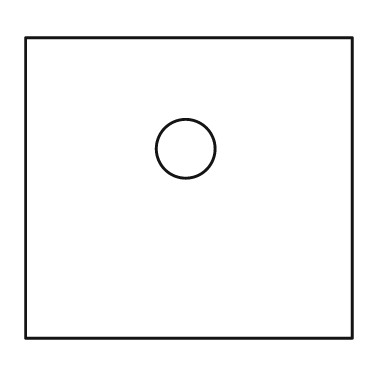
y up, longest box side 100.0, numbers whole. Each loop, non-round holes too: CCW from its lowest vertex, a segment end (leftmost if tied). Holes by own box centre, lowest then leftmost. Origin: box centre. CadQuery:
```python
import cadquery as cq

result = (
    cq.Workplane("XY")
    .moveTo(-50.0, -46.0)
    .lineTo(50.0, -46.0)
    .lineTo(50.0, 46.0)
    .lineTo(-50.0, 46.0)
    .close()
    .moveTo(-1.0, 12.0)
    .circle(9.0)
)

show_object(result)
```